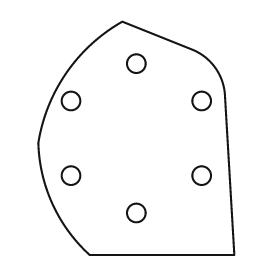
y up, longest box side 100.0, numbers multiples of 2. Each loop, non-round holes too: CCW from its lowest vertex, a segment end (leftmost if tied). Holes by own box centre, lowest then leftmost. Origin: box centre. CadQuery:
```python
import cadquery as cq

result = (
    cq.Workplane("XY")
    .moveTo(-20.0, -50.0)
    .lineTo(42.0, -50.0)
    .lineTo(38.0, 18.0)
    .threePointArc((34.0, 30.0), (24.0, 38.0))
    .lineTo(-6.0, 50.0)
    .threePointArc((-30.0, 28.0), (-42.0, -2.0))
    .threePointArc((-36.0, -28.0), (-20.0, -50.0))
    .close()
    .moveTo(0.0, -32.0)
    .circle(4.0)
    .moveTo(-28.0, -16.0)
    .circle(4.0)
    .moveTo(28.0, -16.0)
    .circle(4.0)
    .moveTo(-28.0, 16.0)
    .circle(4.0)
    .moveTo(28.0, 16.0)
    .circle(4.0)
    .moveTo(0.0, 32.0)
    .circle(4.0)
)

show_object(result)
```